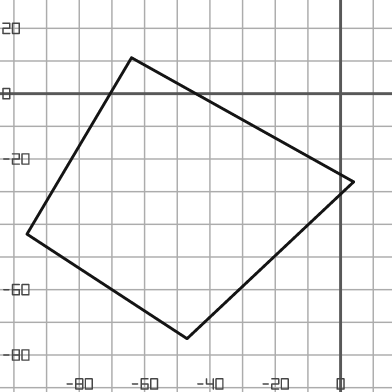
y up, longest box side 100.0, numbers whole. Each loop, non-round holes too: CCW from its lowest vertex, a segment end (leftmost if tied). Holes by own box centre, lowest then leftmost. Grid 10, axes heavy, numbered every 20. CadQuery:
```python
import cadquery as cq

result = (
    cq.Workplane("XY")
    .moveTo(-47.0, -75.0)
    .lineTo(4.0, -27.0)
    .lineTo(-64.0, 11.0)
    .lineTo(-96.0, -43.0)
    .close()
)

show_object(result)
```